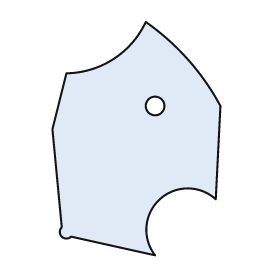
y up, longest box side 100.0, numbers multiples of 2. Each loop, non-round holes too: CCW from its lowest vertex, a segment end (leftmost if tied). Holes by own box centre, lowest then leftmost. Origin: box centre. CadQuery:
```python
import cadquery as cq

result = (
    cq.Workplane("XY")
    .moveTo(8.0, -50.0)
    .threePointArc((10.0, -26.0), (34.0, -26.0))
    .lineTo(36.0, 14.0)
    .threePointArc((22.0, 34.0), (4.0, 50.0))
    .threePointArc((-10.0, 34.0), (-30.0, 28.0))
    .lineTo(-36.0, 4.0)
    .lineTo(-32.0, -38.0)
    .threePointArc((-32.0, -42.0), (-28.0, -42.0))
    .close()
    .moveTo(8.0, 14.0)
    .circle(4.0)
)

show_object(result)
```